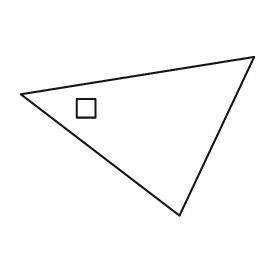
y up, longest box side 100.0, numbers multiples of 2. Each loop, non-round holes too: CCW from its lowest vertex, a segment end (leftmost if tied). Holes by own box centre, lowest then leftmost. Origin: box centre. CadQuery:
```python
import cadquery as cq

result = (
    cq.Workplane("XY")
    .moveTo(18.0, -34.0)
    .lineTo(50.0, 34.0)
    .lineTo(-50.0, 18.0)
    .close()
    .moveTo(-26.0, 8.0)
    .lineTo(-18.0, 8.0)
    .lineTo(-18.0, 16.0)
    .lineTo(-26.0, 16.0)
    .close()
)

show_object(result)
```